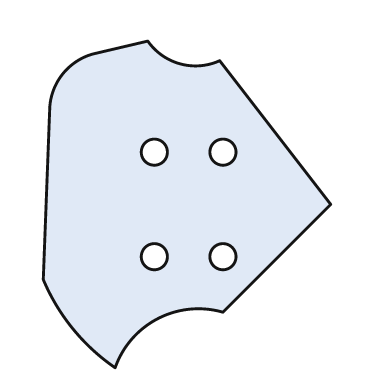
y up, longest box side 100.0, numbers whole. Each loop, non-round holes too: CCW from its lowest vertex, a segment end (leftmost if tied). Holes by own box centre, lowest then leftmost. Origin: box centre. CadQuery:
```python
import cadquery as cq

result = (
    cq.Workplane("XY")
    .moveTo(-22.0, -50.0)
    .threePointArc((-9.0, -35.0), (11.0, -33.0))
    .lineTo(44.0, 0.0)
    .lineTo(10.0, 44.0)
    .threePointArc((-2.0, 43.0), (-12.0, 50.0))
    .lineTo(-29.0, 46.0)
    .threePointArc((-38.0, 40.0), (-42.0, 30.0))
    .lineTo(-44.0, -23.0)
    .threePointArc((-35.0, -38.0), (-22.0, -50.0))
    .close()
    .moveTo(-10.0, -16.0)
    .circle(4.0)
    .moveTo(11.0, -16.0)
    .circle(4.0)
    .moveTo(-10.0, 16.0)
    .circle(4.0)
    .moveTo(11.0, 16.0)
    .circle(4.0)
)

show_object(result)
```